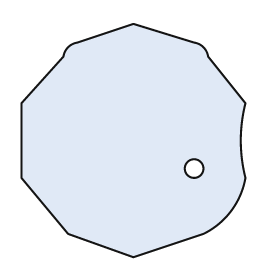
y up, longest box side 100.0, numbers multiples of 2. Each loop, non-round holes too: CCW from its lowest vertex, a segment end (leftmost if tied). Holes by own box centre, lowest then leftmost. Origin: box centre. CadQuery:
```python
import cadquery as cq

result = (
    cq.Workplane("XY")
    .moveTo(0.0, -50.0)
    .lineTo(30.0, -40.0)
    .threePointArc((42.0, -30.0), (48.0, -16.0))
    .threePointArc((46.0, 0.0), (48.0, 16.0))
    .lineTo(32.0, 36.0)
    .threePointArc((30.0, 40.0), (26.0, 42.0))
    .lineTo(0.0, 50.0)
    .lineTo(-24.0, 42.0)
    .threePointArc((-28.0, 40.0), (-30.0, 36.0))
    .lineTo(-48.0, 16.0)
    .lineTo(-48.0, -16.0)
    .lineTo(-28.0, -40.0)
    .close()
    .moveTo(26.0, -12.0)
    .circle(4.0)
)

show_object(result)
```